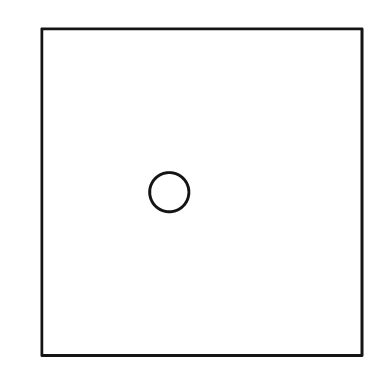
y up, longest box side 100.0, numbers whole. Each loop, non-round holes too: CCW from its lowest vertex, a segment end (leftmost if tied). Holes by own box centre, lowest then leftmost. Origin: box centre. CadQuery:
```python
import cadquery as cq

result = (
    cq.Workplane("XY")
    .moveTo(-49.0, -50.0)
    .lineTo(49.0, -50.0)
    .lineTo(49.0, 50.0)
    .lineTo(-49.0, 50.0)
    .close()
    .moveTo(-10.0, 0.0)
    .circle(6.0)
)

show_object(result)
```